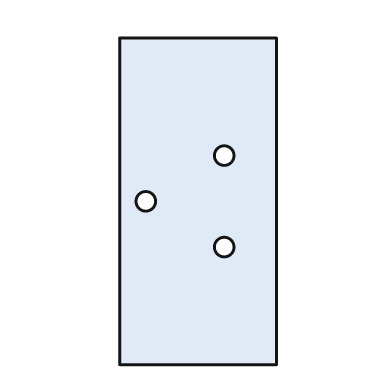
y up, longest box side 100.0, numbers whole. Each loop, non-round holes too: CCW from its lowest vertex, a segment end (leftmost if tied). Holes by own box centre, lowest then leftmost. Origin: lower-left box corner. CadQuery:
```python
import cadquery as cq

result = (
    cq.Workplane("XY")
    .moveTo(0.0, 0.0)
    .lineTo(48.0, 0.0)
    .lineTo(48.0, 100.0)
    .lineTo(0.0, 100.0)
    .close()
    .moveTo(32.0, 36.0)
    .circle(3.0)
    .moveTo(8.0, 50.0)
    .circle(3.0)
    .moveTo(32.0, 64.0)
    .circle(3.0)
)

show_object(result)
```